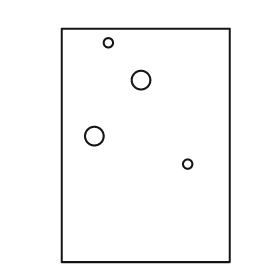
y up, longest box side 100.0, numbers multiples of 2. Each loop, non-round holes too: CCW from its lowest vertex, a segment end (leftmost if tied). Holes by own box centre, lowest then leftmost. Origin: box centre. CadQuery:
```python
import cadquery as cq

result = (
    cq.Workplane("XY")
    .moveTo(-36.0, -50.0)
    .lineTo(36.0, -50.0)
    .lineTo(36.0, 50.0)
    .lineTo(-36.0, 50.0)
    .close()
    .moveTo(18.0, -8.0)
    .circle(2.0)
    .moveTo(-22.0, 4.0)
    .circle(4.0)
    .moveTo(-2.0, 28.0)
    .circle(4.0)
    .moveTo(-16.0, 44.0)
    .circle(2.0)
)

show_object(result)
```